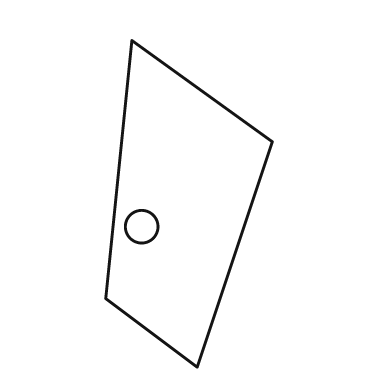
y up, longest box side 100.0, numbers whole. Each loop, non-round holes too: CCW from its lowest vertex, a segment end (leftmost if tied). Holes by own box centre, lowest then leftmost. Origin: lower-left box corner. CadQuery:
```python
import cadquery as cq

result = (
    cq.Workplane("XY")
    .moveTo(28.0, 0.0)
    .lineTo(51.0, 69.0)
    .lineTo(8.0, 100.0)
    .lineTo(0.0, 21.0)
    .close()
    .moveTo(11.0, 43.0)
    .circle(5.0)
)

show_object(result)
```